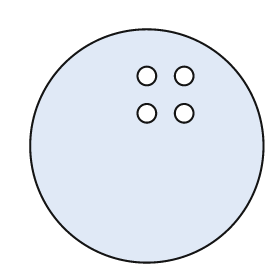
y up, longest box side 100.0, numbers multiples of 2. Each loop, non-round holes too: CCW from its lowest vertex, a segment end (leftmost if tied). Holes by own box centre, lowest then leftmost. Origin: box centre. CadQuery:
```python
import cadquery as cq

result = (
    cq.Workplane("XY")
    .moveTo(0.0, 0.0)
    .circle(50.0)
    .moveTo(0.0, 14.0)
    .circle(4.0)
    .moveTo(16.0, 14.0)
    .circle(4.0)
    .moveTo(0.0, 30.0)
    .circle(4.0)
    .moveTo(16.0, 30.0)
    .circle(4.0)
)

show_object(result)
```